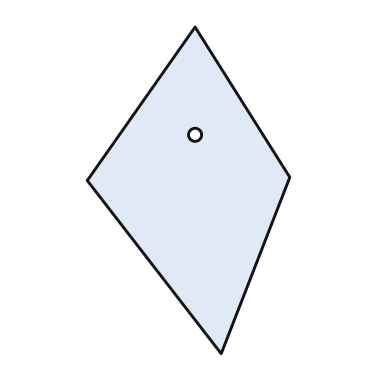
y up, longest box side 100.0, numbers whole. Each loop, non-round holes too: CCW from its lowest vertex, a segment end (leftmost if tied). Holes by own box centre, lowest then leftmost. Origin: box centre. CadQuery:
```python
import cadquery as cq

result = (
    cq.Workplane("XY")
    .moveTo(10.0, -50.0)
    .lineTo(31.0, 4.0)
    .lineTo(2.0, 50.0)
    .lineTo(-31.0, 3.0)
    .close()
    .moveTo(2.0, 17.0)
    .circle(2.0)
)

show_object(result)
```